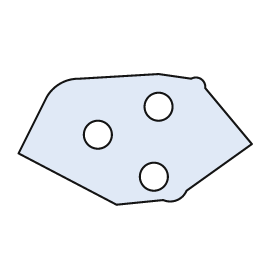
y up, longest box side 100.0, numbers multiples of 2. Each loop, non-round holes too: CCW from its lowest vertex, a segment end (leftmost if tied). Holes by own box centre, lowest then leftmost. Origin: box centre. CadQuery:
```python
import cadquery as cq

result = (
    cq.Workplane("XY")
    .moveTo(-8.0, -28.0)
    .lineTo(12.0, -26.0)
    .threePointArc((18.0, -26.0), (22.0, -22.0))
    .lineTo(50.0, -2.0)
    .lineTo(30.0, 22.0)
    .threePointArc((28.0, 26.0), (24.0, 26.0))
    .lineTo(10.0, 28.0)
    .lineTo(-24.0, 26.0)
    .threePointArc((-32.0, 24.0), (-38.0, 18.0))
    .lineTo(-50.0, -6.0)
    .close()
    .moveTo(8.0, -16.0)
    .circle(6.0)
    .moveTo(-16.0, 2.0)
    .circle(6.0)
    .moveTo(10.0, 14.0)
    .circle(6.0)
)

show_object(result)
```